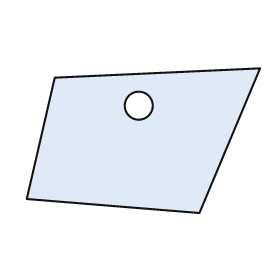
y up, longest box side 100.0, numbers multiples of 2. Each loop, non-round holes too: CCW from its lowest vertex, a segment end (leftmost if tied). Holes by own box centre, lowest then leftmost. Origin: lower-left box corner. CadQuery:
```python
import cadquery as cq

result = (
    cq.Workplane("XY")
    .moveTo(74.0, 0.0)
    .lineTo(100.0, 62.0)
    .lineTo(12.0, 58.0)
    .lineTo(0.0, 6.0)
    .close()
    .moveTo(48.0, 46.0)
    .circle(6.0)
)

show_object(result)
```